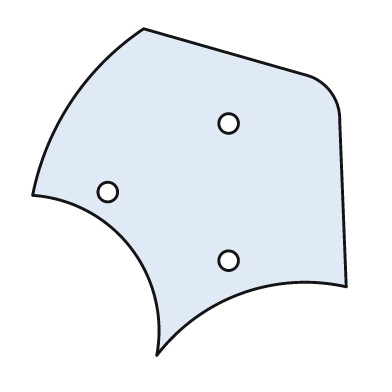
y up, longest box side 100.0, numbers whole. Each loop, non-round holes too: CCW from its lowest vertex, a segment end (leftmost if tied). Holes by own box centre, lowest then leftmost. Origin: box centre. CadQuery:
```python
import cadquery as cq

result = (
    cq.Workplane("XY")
    .moveTo(-10.0, -50.0)
    .threePointArc((16.0, -31.0), (48.0, -29.0))
    .lineTo(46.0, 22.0)
    .threePointArc((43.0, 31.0), (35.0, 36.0))
    .lineTo(-14.0, 50.0)
    .threePointArc((-36.0, 28.0), (-48.0, -1.0))
    .threePointArc((-18.0, -17.0), (-10.0, -50.0))
    .close()
    .moveTo(12.0, -21.0)
    .circle(3.0)
    .moveTo(-25.0, 0.0)
    .circle(3.0)
    .moveTo(12.0, 21.0)
    .circle(3.0)
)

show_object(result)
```